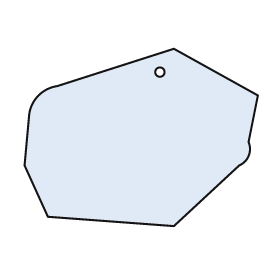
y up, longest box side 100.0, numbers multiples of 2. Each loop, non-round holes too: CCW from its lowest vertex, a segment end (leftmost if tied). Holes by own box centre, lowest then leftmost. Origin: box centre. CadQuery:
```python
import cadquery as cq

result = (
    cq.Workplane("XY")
    .moveTo(14.0, -38.0)
    .lineTo(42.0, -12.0)
    .threePointArc((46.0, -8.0), (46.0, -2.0))
    .lineTo(50.0, 18.0)
    .lineTo(14.0, 38.0)
    .lineTo(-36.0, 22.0)
    .threePointArc((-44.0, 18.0), (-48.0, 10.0))
    .lineTo(-50.0, -12.0)
    .lineTo(-40.0, -34.0)
    .close()
    .moveTo(8.0, 28.0)
    .circle(2.0)
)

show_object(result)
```